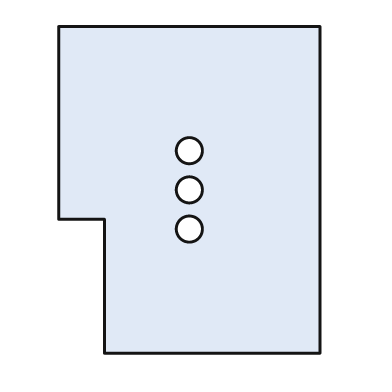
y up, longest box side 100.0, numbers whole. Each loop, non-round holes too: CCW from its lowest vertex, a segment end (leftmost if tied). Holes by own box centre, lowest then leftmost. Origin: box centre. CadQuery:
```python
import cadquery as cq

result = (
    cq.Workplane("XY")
    .moveTo(-26.0, -50.0)
    .lineTo(40.0, -50.0)
    .lineTo(40.0, 50.0)
    .lineTo(-40.0, 50.0)
    .lineTo(-40.0, -9.0)
    .lineTo(-26.0, -9.0)
    .close()
    .moveTo(0.0, -12.0)
    .circle(4.0)
    .moveTo(0.0, 0.0)
    .circle(4.0)
    .moveTo(0.0, 12.0)
    .circle(4.0)
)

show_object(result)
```